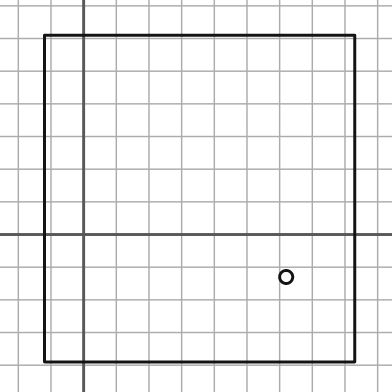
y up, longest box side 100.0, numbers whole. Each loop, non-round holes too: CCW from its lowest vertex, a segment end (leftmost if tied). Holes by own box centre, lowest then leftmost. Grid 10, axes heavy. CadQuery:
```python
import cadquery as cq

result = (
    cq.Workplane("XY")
    .moveTo(-12.0, -39.0)
    .lineTo(83.0, -39.0)
    .lineTo(83.0, 61.0)
    .lineTo(-12.0, 61.0)
    .close()
    .moveTo(62.0, -13.0)
    .circle(2.0)
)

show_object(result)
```